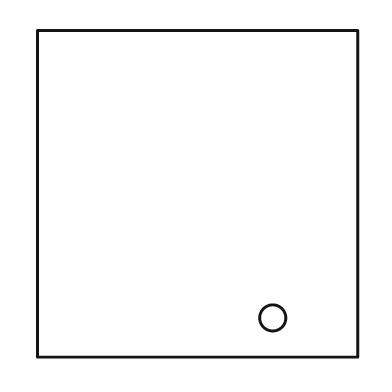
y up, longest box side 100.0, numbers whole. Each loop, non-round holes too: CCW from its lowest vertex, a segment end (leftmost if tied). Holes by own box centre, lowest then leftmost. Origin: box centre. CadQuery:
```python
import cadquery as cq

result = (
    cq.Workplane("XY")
    .moveTo(-49.0, -50.0)
    .lineTo(49.0, -50.0)
    .lineTo(49.0, 50.0)
    .lineTo(-49.0, 50.0)
    .close()
    .moveTo(23.0, -38.0)
    .circle(4.0)
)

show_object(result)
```